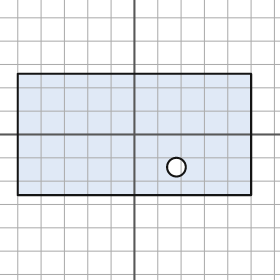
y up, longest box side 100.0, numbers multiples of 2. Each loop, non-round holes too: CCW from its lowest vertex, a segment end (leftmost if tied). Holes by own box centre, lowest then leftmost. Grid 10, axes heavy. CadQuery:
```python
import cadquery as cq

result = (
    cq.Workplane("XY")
    .moveTo(-50.0, -26.0)
    .lineTo(50.0, -26.0)
    .lineTo(50.0, 26.0)
    .lineTo(-50.0, 26.0)
    .close()
    .moveTo(18.0, -14.0)
    .circle(4.0)
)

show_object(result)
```